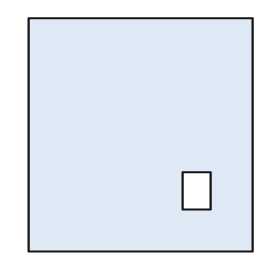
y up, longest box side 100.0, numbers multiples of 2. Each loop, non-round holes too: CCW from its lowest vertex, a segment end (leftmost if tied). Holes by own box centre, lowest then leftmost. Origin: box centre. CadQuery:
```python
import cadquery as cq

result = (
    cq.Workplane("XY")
    .moveTo(-48.0, -50.0)
    .lineTo(48.0, -50.0)
    .lineTo(48.0, 50.0)
    .lineTo(-48.0, 50.0)
    .close()
    .moveTo(18.0, -32.0)
    .lineTo(30.0, -32.0)
    .lineTo(30.0, -16.0)
    .lineTo(18.0, -16.0)
    .close()
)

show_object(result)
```